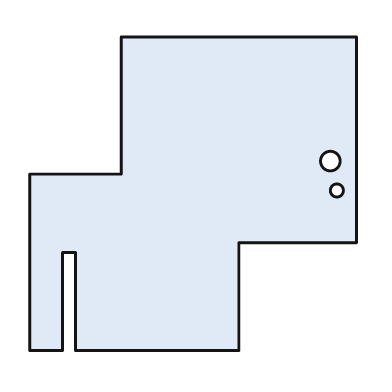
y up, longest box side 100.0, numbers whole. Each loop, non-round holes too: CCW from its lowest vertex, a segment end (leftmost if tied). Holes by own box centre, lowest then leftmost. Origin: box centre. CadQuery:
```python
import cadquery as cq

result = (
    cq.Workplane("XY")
    .moveTo(-50.0, -48.0)
    .lineTo(-40.0, -48.0)
    .lineTo(-40.0, -18.0)
    .lineTo(-36.0, -18.0)
    .lineTo(-36.0, -48.0)
    .lineTo(14.0, -48.0)
    .lineTo(14.0, -15.0)
    .lineTo(50.0, -15.0)
    .lineTo(50.0, 48.0)
    .lineTo(-22.0, 48.0)
    .lineTo(-22.0, 6.0)
    .lineTo(-50.0, 6.0)
    .close()
    .moveTo(44.0, 1.0)
    .circle(2.0)
    .moveTo(42.0, 10.0)
    .circle(3.0)
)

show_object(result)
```